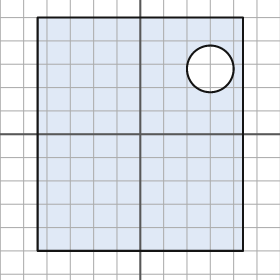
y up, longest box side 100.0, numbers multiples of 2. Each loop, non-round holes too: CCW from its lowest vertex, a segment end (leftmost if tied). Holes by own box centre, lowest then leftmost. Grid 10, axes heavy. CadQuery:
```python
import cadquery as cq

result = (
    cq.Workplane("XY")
    .moveTo(-44.0, -50.0)
    .lineTo(44.0, -50.0)
    .lineTo(44.0, 50.0)
    .lineTo(-44.0, 50.0)
    .close()
    .moveTo(30.0, 28.0)
    .circle(10.0)
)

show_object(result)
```